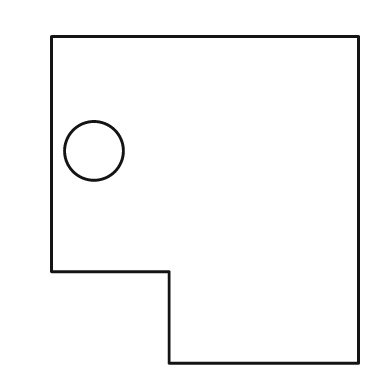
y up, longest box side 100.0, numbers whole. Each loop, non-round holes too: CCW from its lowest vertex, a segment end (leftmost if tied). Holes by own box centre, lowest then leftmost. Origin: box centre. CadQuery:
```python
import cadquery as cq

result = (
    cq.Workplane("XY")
    .moveTo(-11.0, -50.0)
    .lineTo(47.0, -50.0)
    .lineTo(47.0, 50.0)
    .lineTo(-47.0, 50.0)
    .lineTo(-47.0, -22.0)
    .lineTo(-11.0, -22.0)
    .close()
    .moveTo(-34.0, 15.0)
    .circle(9.0)
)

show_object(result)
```